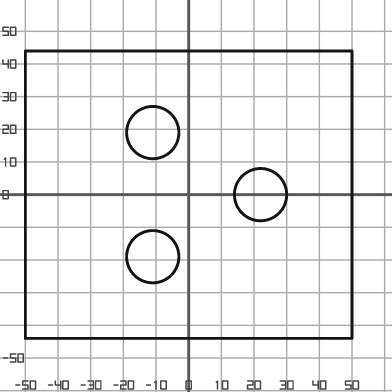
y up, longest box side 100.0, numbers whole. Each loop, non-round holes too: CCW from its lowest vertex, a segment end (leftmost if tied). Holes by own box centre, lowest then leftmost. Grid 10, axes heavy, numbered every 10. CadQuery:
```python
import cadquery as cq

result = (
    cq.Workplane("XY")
    .moveTo(-50.0, -44.0)
    .lineTo(50.0, -44.0)
    .lineTo(50.0, 44.0)
    .lineTo(-50.0, 44.0)
    .close()
    .moveTo(-11.0, -19.0)
    .circle(8.0)
    .moveTo(22.0, 0.0)
    .circle(8.0)
    .moveTo(-11.0, 19.0)
    .circle(8.0)
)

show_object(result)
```